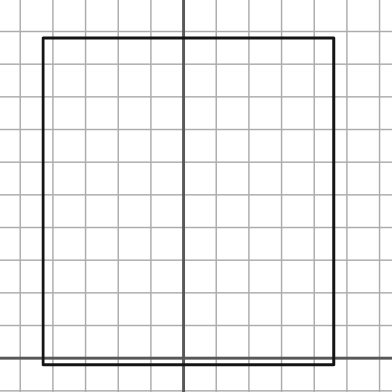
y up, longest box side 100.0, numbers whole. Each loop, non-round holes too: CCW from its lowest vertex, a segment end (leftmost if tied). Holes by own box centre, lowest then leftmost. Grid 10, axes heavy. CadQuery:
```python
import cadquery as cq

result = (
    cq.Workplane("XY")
    .moveTo(-43.0, -2.0)
    .lineTo(46.0, -2.0)
    .lineTo(46.0, 98.0)
    .lineTo(-43.0, 98.0)
    .close()
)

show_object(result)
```